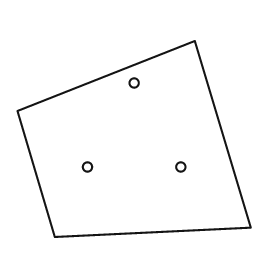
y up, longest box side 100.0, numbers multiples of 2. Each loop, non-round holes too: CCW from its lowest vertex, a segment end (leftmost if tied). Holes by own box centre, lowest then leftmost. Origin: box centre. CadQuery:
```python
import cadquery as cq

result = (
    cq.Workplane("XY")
    .moveTo(-34.0, -42.0)
    .lineTo(50.0, -38.0)
    .lineTo(26.0, 42.0)
    .lineTo(-50.0, 12.0)
    .close()
    .moveTo(-20.0, -12.0)
    .circle(2.0)
    .moveTo(20.0, -12.0)
    .circle(2.0)
    .moveTo(0.0, 24.0)
    .circle(2.0)
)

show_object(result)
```